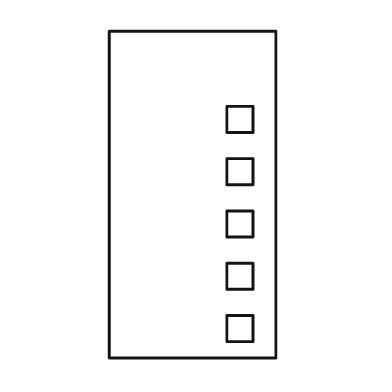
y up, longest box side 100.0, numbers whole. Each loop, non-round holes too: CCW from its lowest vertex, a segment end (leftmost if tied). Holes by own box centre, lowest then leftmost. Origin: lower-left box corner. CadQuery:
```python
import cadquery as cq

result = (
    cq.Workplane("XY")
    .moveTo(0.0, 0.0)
    .lineTo(51.0, 0.0)
    .lineTo(51.0, 100.0)
    .lineTo(0.0, 100.0)
    .close()
    .moveTo(36.0, 5.0)
    .lineTo(44.0, 5.0)
    .lineTo(44.0, 13.0)
    .lineTo(36.0, 13.0)
    .close()
    .moveTo(36.0, 21.0)
    .lineTo(44.0, 21.0)
    .lineTo(44.0, 29.0)
    .lineTo(36.0, 29.0)
    .close()
    .moveTo(36.0, 37.0)
    .lineTo(44.0, 37.0)
    .lineTo(44.0, 45.0)
    .lineTo(36.0, 45.0)
    .close()
    .moveTo(36.0, 53.0)
    .lineTo(44.0, 53.0)
    .lineTo(44.0, 61.0)
    .lineTo(36.0, 61.0)
    .close()
    .moveTo(36.0, 69.0)
    .lineTo(44.0, 69.0)
    .lineTo(44.0, 77.0)
    .lineTo(36.0, 77.0)
    .close()
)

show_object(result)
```